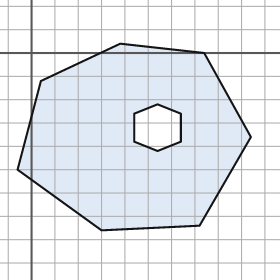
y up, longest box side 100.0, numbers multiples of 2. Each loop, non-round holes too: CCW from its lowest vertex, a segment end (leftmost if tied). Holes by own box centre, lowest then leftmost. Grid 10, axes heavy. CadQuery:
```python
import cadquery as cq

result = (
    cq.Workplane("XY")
    .moveTo(30.0, -76.0)
    .lineTo(72.0, -74.0)
    .lineTo(94.0, -36.0)
    .lineTo(74.0, 0.0)
    .lineTo(38.0, 4.0)
    .lineTo(4.0, -12.0)
    .lineTo(-6.0, -50.0)
    .close()
    .moveTo(54.0, -42.0)
    .lineTo(64.0, -38.0)
    .lineTo(64.0, -26.0)
    .lineTo(54.0, -22.0)
    .lineTo(44.0, -26.0)
    .lineTo(44.0, -38.0)
    .close()
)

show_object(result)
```